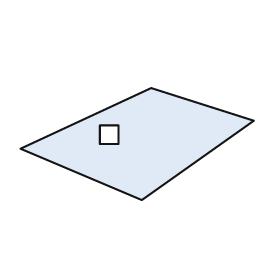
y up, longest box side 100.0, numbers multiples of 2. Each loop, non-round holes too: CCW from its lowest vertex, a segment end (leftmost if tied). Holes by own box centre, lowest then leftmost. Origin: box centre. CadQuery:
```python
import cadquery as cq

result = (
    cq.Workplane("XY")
    .moveTo(2.0, -24.0)
    .lineTo(50.0, 10.0)
    .lineTo(6.0, 24.0)
    .lineTo(-50.0, -2.0)
    .close()
    .moveTo(-16.0, 0.0)
    .lineTo(-8.0, 0.0)
    .lineTo(-8.0, 8.0)
    .lineTo(-16.0, 8.0)
    .close()
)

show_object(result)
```